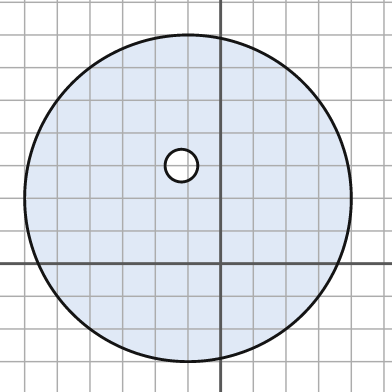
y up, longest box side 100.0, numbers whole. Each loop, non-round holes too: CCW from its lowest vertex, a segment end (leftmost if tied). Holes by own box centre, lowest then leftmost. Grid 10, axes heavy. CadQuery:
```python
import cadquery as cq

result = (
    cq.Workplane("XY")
    .moveTo(-10.0, 20.0)
    .circle(50.0)
    .moveTo(-12.0, 30.0)
    .circle(5.0)
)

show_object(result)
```